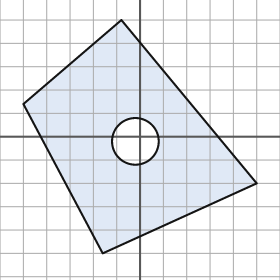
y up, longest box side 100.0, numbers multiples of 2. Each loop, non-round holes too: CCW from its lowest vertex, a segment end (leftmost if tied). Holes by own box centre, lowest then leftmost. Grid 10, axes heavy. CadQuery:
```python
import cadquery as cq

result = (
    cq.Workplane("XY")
    .moveTo(-16.0, -50.0)
    .lineTo(50.0, -20.0)
    .lineTo(-8.0, 50.0)
    .lineTo(-50.0, 14.0)
    .close()
    .moveTo(-2.0, -2.0)
    .circle(10.0)
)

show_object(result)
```